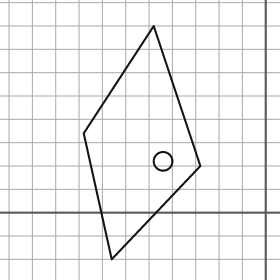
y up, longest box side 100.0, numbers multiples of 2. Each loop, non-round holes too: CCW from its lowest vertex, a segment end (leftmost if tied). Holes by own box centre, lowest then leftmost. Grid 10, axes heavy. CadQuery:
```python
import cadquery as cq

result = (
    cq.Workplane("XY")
    .moveTo(-66.0, -20.0)
    .lineTo(-28.0, 20.0)
    .lineTo(-48.0, 80.0)
    .lineTo(-78.0, 34.0)
    .close()
    .moveTo(-44.0, 22.0)
    .circle(4.0)
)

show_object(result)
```